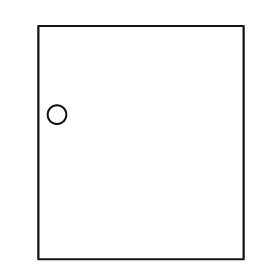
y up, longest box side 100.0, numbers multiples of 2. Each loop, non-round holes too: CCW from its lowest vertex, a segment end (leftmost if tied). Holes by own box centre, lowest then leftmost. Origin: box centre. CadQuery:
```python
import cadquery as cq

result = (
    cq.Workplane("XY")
    .moveTo(-44.0, -50.0)
    .lineTo(44.0, -50.0)
    .lineTo(44.0, 50.0)
    .lineTo(-44.0, 50.0)
    .close()
    .moveTo(-36.0, 12.0)
    .circle(4.0)
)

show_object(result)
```